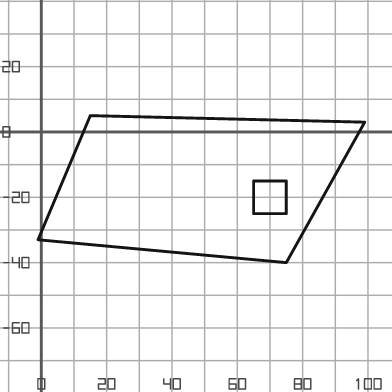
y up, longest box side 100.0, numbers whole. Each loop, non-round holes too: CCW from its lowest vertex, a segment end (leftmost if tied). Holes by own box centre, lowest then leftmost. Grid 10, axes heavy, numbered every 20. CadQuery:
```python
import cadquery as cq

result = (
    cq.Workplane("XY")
    .moveTo(75.0, -40.0)
    .lineTo(99.0, 3.0)
    .lineTo(15.0, 5.0)
    .lineTo(-1.0, -33.0)
    .close()
    .moveTo(65.0, -25.0)
    .lineTo(75.0, -25.0)
    .lineTo(75.0, -15.0)
    .lineTo(65.0, -15.0)
    .close()
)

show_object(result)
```